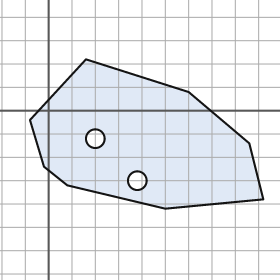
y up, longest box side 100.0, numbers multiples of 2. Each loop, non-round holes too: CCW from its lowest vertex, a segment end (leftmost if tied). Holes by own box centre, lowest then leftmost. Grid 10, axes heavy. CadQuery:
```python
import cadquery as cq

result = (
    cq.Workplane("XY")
    .moveTo(50.0, -42.0)
    .lineTo(92.0, -38.0)
    .lineTo(86.0, -14.0)
    .lineTo(60.0, 8.0)
    .lineTo(16.0, 22.0)
    .lineTo(-8.0, -4.0)
    .lineTo(-2.0, -24.0)
    .lineTo(8.0, -32.0)
    .close()
    .moveTo(38.0, -30.0)
    .circle(4.0)
    .moveTo(20.0, -12.0)
    .circle(4.0)
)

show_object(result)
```